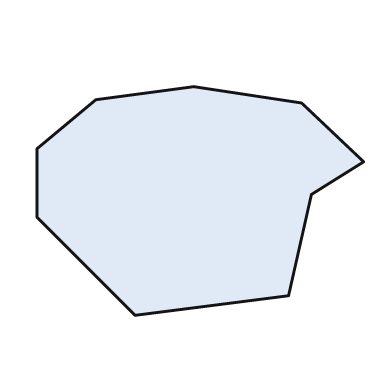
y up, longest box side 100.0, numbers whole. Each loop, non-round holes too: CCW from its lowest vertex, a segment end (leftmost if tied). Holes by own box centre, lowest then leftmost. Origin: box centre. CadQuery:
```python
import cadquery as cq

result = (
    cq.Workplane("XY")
    .moveTo(-20.0, -35.0)
    .lineTo(27.0, -29.0)
    .lineTo(34.0, 2.0)
    .lineTo(50.0, 12.0)
    .lineTo(31.0, 30.0)
    .lineTo(-2.0, 35.0)
    .lineTo(-32.0, 31.0)
    .lineTo(-50.0, 16.0)
    .lineTo(-50.0, -5.0)
    .close()
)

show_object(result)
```